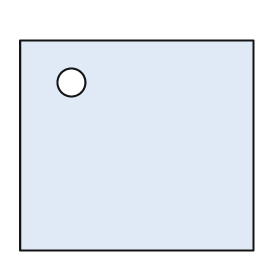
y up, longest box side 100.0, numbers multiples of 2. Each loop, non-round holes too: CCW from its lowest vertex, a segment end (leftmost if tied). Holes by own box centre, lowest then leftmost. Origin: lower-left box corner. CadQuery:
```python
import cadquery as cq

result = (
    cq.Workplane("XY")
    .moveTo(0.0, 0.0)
    .lineTo(100.0, 0.0)
    .lineTo(100.0, 90.0)
    .lineTo(0.0, 90.0)
    .close()
    .moveTo(22.0, 72.0)
    .circle(6.0)
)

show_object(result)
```